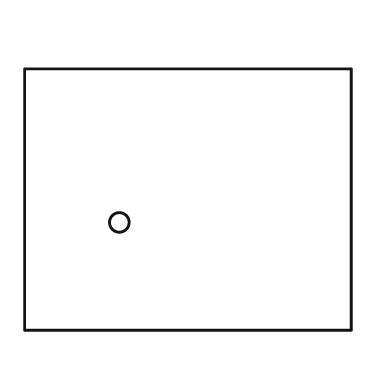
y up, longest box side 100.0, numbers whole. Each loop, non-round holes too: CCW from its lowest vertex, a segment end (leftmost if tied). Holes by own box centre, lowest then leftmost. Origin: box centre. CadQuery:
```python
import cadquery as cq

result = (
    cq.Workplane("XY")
    .moveTo(-50.0, -40.0)
    .lineTo(50.0, -40.0)
    .lineTo(50.0, 40.0)
    .lineTo(-50.0, 40.0)
    .close()
    .moveTo(-21.0, -7.0)
    .circle(3.0)
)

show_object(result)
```